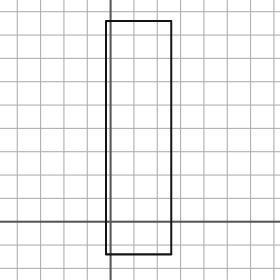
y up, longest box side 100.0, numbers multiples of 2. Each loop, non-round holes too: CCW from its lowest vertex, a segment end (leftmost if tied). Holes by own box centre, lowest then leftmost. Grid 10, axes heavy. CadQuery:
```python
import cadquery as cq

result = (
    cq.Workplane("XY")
    .moveTo(-2.0, -14.0)
    .lineTo(26.0, -14.0)
    .lineTo(26.0, 86.0)
    .lineTo(-2.0, 86.0)
    .close()
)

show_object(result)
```